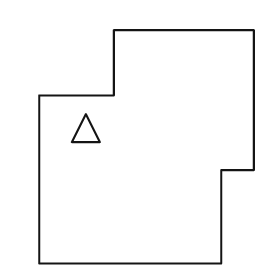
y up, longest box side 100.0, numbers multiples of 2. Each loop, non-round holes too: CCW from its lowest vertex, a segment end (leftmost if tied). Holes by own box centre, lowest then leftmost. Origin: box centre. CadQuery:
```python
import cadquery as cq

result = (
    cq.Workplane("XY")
    .moveTo(-46.0, -50.0)
    .lineTo(32.0, -50.0)
    .lineTo(32.0, -10.0)
    .lineTo(46.0, -10.0)
    .lineTo(46.0, 50.0)
    .lineTo(-14.0, 50.0)
    .lineTo(-14.0, 22.0)
    .lineTo(-46.0, 22.0)
    .close()
    .moveTo(-32.0, 2.0)
    .lineTo(-20.0, 2.0)
    .lineTo(-26.0, 14.0)
    .close()
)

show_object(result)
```